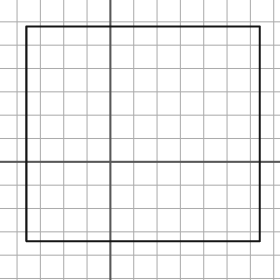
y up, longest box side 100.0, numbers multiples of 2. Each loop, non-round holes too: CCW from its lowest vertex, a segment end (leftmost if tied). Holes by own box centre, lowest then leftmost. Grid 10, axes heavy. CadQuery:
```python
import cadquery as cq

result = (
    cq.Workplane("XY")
    .moveTo(-36.0, -34.0)
    .lineTo(64.0, -34.0)
    .lineTo(64.0, 58.0)
    .lineTo(-36.0, 58.0)
    .close()
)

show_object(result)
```